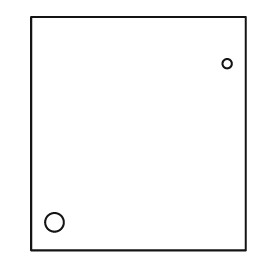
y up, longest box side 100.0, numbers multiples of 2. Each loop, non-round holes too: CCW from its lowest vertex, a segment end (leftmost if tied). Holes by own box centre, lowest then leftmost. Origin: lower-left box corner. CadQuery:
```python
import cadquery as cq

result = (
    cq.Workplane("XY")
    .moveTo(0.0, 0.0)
    .lineTo(92.0, 0.0)
    .lineTo(92.0, 100.0)
    .lineTo(0.0, 100.0)
    .close()
    .moveTo(10.0, 12.0)
    .circle(4.0)
    .moveTo(84.0, 80.0)
    .circle(2.0)
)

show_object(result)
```